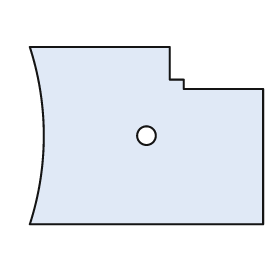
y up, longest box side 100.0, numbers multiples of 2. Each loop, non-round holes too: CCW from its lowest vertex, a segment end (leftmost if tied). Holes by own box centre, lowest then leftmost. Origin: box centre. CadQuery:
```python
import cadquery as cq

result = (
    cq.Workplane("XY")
    .moveTo(-50.0, -38.0)
    .lineTo(50.0, -38.0)
    .lineTo(50.0, 20.0)
    .lineTo(16.0, 20.0)
    .lineTo(16.0, 24.0)
    .lineTo(10.0, 24.0)
    .lineTo(10.0, 38.0)
    .lineTo(-50.0, 38.0)
    .threePointArc((-44.0, 0.0), (-50.0, -38.0))
    .close()
    .moveTo(0.0, 0.0)
    .circle(4.0)
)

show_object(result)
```